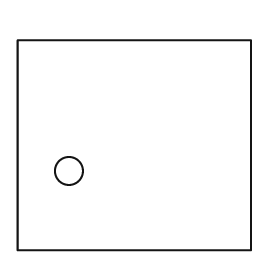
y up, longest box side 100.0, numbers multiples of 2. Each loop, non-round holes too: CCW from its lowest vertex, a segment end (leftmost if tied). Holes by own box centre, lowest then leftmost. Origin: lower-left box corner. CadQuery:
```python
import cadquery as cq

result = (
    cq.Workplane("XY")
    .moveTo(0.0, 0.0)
    .lineTo(100.0, 0.0)
    .lineTo(100.0, 90.0)
    .lineTo(0.0, 90.0)
    .close()
    .moveTo(22.0, 34.0)
    .circle(6.0)
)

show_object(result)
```